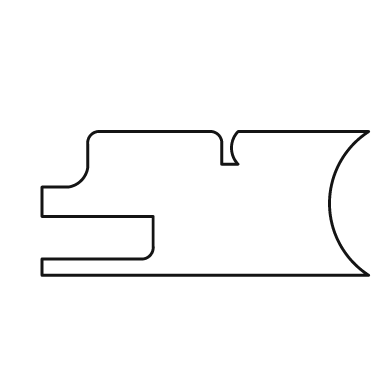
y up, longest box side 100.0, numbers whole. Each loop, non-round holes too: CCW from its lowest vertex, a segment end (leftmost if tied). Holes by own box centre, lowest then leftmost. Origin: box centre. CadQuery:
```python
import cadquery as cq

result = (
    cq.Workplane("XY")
    .moveTo(-50.0, -22.0)
    .lineTo(50.0, -22.0)
    .threePointArc((38.0, 0.0), (50.0, 22.0))
    .lineTo(10.0, 22.0)
    .threePointArc((8.0, 17.0), (10.0, 12.0))
    .lineTo(5.0, 12.0)
    .lineTo(5.0, 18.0)
    .threePointArc((4.0, 21.0), (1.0, 22.0))
    .lineTo(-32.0, 22.0)
    .threePointArc((-35.0, 21.0), (-36.0, 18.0))
    .lineTo(-36.0, 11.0)
    .threePointArc((-38.0, 7.0), (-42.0, 5.0))
    .lineTo(-50.0, 5.0)
    .lineTo(-50.0, -4.0)
    .lineTo(-16.0, -4.0)
    .lineTo(-16.0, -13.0)
    .threePointArc((-17.0, -16.0), (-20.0, -17.0))
    .lineTo(-50.0, -17.0)
    .close()
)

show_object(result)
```